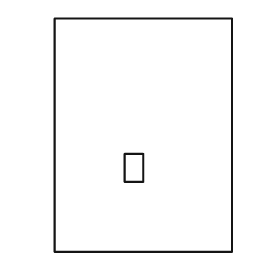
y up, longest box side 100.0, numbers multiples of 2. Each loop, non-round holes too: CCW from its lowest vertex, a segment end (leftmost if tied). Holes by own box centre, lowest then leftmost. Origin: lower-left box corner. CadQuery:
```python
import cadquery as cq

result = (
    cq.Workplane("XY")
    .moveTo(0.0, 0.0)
    .lineTo(76.0, 0.0)
    .lineTo(76.0, 100.0)
    .lineTo(0.0, 100.0)
    .close()
    .moveTo(30.0, 30.0)
    .lineTo(38.0, 30.0)
    .lineTo(38.0, 42.0)
    .lineTo(30.0, 42.0)
    .close()
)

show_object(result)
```